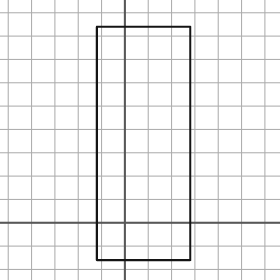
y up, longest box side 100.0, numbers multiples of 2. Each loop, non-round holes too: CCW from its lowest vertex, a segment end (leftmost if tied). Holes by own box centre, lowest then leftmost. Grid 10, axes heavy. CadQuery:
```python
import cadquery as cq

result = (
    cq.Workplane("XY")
    .moveTo(-12.0, -16.0)
    .lineTo(28.0, -16.0)
    .lineTo(28.0, 84.0)
    .lineTo(-12.0, 84.0)
    .close()
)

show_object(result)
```